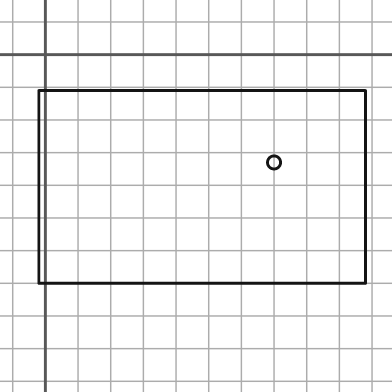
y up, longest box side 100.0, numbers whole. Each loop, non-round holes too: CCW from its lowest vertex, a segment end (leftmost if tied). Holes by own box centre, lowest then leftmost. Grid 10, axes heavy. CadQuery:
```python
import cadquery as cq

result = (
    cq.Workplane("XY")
    .moveTo(-2.0, -70.0)
    .lineTo(98.0, -70.0)
    .lineTo(98.0, -11.0)
    .lineTo(-2.0, -11.0)
    .close()
    .moveTo(70.0, -33.0)
    .circle(2.0)
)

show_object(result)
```